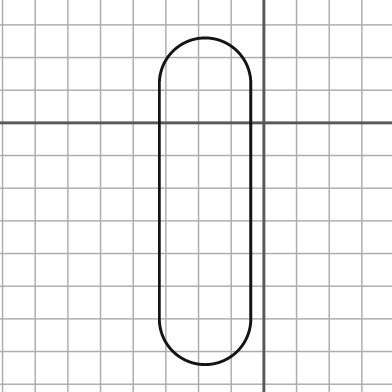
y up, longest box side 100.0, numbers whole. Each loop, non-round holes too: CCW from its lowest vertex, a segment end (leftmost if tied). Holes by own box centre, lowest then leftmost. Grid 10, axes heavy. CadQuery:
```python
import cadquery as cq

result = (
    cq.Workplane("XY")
    .moveTo(-32.0, -60.0)
    .threePointArc((-18.0, -74.0), (-4.0, -60.0))
    .lineTo(-4.0, 12.0)
    .threePointArc((-18.0, 26.0), (-32.0, 12.0))
    .close()
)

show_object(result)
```